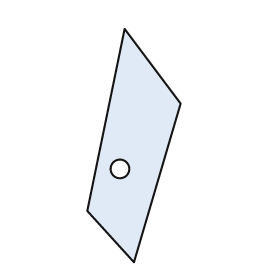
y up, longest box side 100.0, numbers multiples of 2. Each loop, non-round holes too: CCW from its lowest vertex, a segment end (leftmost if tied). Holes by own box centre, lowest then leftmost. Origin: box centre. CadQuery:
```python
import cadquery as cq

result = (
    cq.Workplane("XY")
    .moveTo(0.0, -50.0)
    .lineTo(20.0, 18.0)
    .lineTo(-4.0, 50.0)
    .lineTo(-20.0, -28.0)
    .close()
    .moveTo(-6.0, -10.0)
    .circle(4.0)
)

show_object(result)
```